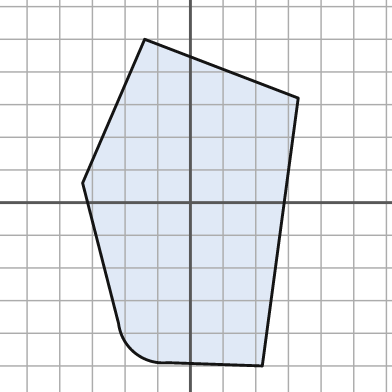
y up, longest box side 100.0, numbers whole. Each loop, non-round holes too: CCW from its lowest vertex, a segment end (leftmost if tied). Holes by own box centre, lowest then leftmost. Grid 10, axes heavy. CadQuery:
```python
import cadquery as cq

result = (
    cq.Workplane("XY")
    .moveTo(22.0, -50.0)
    .lineTo(33.0, 32.0)
    .lineTo(-14.0, 50.0)
    .lineTo(-33.0, 6.0)
    .lineTo(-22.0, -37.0)
    .threePointArc((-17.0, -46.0), (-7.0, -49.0))
    .close()
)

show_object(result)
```